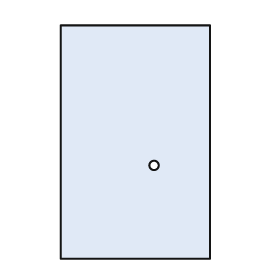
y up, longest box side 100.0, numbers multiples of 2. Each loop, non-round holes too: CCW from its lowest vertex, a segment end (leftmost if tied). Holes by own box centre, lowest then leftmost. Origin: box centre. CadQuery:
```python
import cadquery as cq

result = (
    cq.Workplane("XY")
    .moveTo(-32.0, -50.0)
    .lineTo(32.0, -50.0)
    .lineTo(32.0, 50.0)
    .lineTo(-32.0, 50.0)
    .close()
    .moveTo(8.0, -10.0)
    .circle(2.0)
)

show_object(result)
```